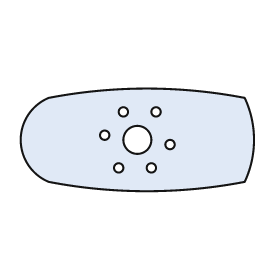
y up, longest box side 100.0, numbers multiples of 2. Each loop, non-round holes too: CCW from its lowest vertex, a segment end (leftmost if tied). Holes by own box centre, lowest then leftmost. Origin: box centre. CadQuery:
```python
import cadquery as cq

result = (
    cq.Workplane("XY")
    .moveTo(-38.0, -18.0)
    .threePointArc((4.0, -22.0), (46.0, -18.0))
    .threePointArc((50.0, 0.0), (46.0, 18.0))
    .threePointArc((4.0, 22.0), (-38.0, 18.0))
    .threePointArc((-50.0, 0.0), (-38.0, -18.0))
    .close()
    .moveTo(-8.0, -12.0)
    .circle(2.0)
    .moveTo(6.0, -12.0)
    .circle(2.0)
    .moveTo(14.0, -2.0)
    .circle(2.0)
    .moveTo(0.0, 0.0)
    .circle(6.0)
    .moveTo(-14.0, 2.0)
    .circle(2.0)
    .moveTo(-6.0, 12.0)
    .circle(2.0)
    .moveTo(8.0, 12.0)
    .circle(2.0)
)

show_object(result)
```